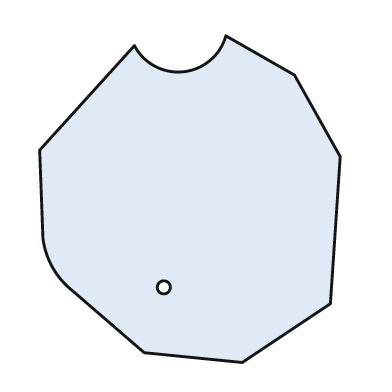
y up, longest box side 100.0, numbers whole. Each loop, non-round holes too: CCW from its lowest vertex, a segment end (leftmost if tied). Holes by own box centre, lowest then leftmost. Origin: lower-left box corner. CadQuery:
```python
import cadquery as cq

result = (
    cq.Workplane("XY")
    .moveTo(62.0, 0.0)
    .lineTo(89.0, 18.0)
    .lineTo(92.0, 63.0)
    .lineTo(78.0, 88.0)
    .lineTo(57.0, 100.0)
    .threePointArc((44.0, 89.0), (29.0, 97.0))
    .lineTo(0.0, 65.0)
    .lineTo(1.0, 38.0)
    .threePointArc((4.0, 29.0), (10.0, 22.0))
    .lineTo(32.0, 3.0)
    .close()
    .moveTo(38.0, 23.0)
    .circle(2.0)
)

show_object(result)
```